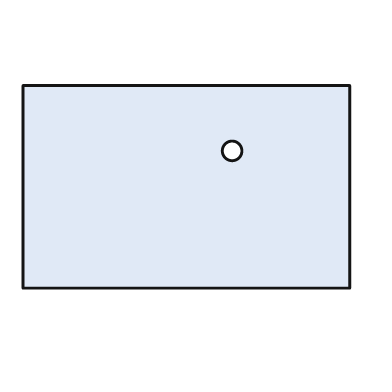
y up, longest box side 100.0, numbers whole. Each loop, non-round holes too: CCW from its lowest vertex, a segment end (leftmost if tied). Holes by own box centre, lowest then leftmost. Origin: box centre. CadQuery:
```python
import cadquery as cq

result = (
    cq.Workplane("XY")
    .moveTo(-50.0, -31.0)
    .lineTo(50.0, -31.0)
    .lineTo(50.0, 31.0)
    .lineTo(-50.0, 31.0)
    .close()
    .moveTo(14.0, 11.0)
    .circle(3.0)
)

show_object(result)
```